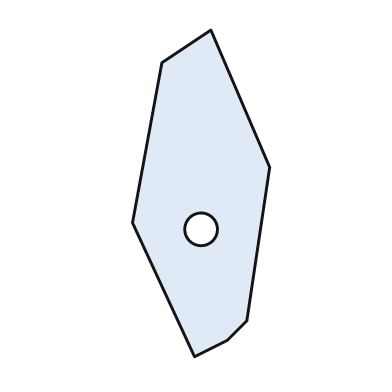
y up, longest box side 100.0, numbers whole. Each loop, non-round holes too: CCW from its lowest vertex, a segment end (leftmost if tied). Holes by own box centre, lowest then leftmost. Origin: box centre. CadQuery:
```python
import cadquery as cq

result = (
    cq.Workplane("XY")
    .moveTo(-2.0, -50.0)
    .lineTo(8.0, -45.0)
    .lineTo(14.0, -39.0)
    .lineTo(21.0, 8.0)
    .lineTo(3.0, 50.0)
    .lineTo(-12.0, 40.0)
    .lineTo(-21.0, -9.0)
    .close()
    .moveTo(0.0, -11.0)
    .circle(5.0)
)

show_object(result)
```